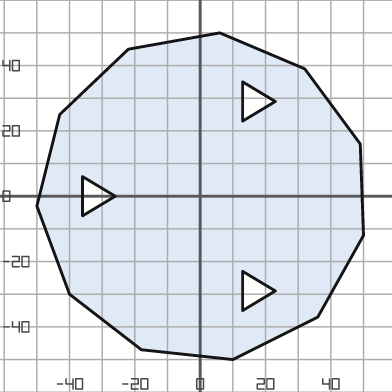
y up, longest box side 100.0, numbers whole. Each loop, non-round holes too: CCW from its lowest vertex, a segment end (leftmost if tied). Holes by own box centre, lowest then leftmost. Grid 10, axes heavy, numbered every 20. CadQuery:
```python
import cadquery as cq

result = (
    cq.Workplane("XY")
    .moveTo(10.0, -50.0)
    .lineTo(36.0, -37.0)
    .lineTo(50.0, -12.0)
    .lineTo(49.0, 16.0)
    .lineTo(32.0, 39.0)
    .lineTo(6.0, 50.0)
    .lineTo(-22.0, 45.0)
    .lineTo(-43.0, 25.0)
    .lineTo(-50.0, -3.0)
    .lineTo(-40.0, -30.0)
    .lineTo(-18.0, -47.0)
    .close()
    .moveTo(13.0, -35.0)
    .lineTo(23.0, -29.0)
    .lineTo(13.0, -23.0)
    .close()
    .moveTo(-36.0, -6.0)
    .lineTo(-26.0, 0.0)
    .lineTo(-36.0, 6.0)
    .close()
    .moveTo(13.0, 23.0)
    .lineTo(23.0, 29.0)
    .lineTo(13.0, 35.0)
    .close()
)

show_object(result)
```